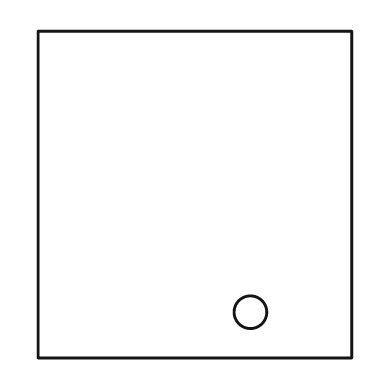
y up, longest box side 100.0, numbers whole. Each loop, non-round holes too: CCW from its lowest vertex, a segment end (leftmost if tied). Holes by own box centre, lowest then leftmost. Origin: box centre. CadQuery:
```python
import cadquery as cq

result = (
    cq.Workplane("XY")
    .moveTo(-48.0, -50.0)
    .lineTo(48.0, -50.0)
    .lineTo(48.0, 50.0)
    .lineTo(-48.0, 50.0)
    .close()
    .moveTo(17.0, -36.0)
    .circle(5.0)
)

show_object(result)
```